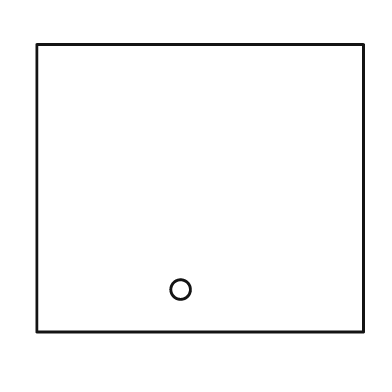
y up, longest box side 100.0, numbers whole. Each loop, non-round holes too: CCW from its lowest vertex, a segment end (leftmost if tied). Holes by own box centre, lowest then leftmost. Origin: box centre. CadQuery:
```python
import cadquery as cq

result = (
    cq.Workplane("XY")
    .moveTo(-50.0, -44.0)
    .lineTo(50.0, -44.0)
    .lineTo(50.0, 44.0)
    .lineTo(-50.0, 44.0)
    .close()
    .moveTo(-6.0, -31.0)
    .circle(3.0)
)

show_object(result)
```